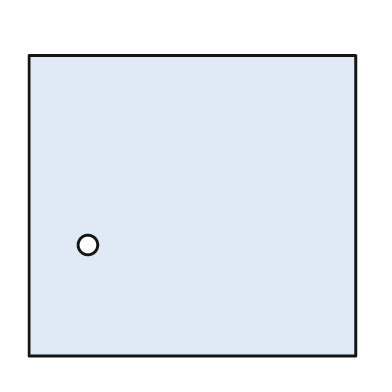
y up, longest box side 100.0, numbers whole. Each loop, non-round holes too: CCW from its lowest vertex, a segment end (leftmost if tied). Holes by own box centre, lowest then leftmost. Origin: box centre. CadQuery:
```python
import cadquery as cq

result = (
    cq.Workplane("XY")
    .moveTo(-50.0, -46.0)
    .lineTo(50.0, -46.0)
    .lineTo(50.0, 46.0)
    .lineTo(-50.0, 46.0)
    .close()
    .moveTo(-32.0, -12.0)
    .circle(3.0)
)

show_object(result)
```